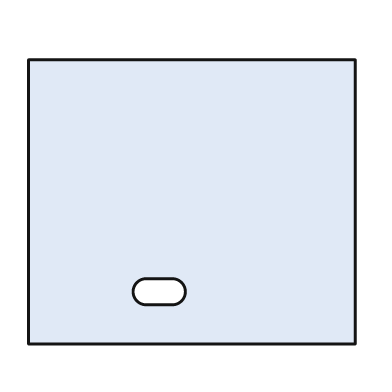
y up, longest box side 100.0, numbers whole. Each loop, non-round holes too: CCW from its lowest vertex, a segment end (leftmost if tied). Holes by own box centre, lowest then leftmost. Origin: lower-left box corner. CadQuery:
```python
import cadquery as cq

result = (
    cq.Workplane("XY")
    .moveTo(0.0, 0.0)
    .lineTo(100.0, 0.0)
    .lineTo(100.0, 87.0)
    .lineTo(0.0, 87.0)
    .close()
    .moveTo(36.0, 12.0)
    .lineTo(44.0, 12.0)
    .threePointArc((48.0, 16.0), (44.0, 20.0))
    .lineTo(36.0, 20.0)
    .threePointArc((32.0, 16.0), (36.0, 12.0))
    .close()
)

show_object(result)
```